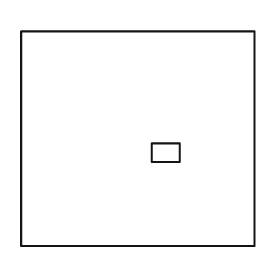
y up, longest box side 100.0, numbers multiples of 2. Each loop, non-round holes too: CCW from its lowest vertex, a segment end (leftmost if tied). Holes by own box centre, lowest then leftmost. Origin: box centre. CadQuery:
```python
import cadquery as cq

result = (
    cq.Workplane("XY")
    .moveTo(-50.0, -46.0)
    .lineTo(50.0, -46.0)
    .lineTo(50.0, 46.0)
    .lineTo(-50.0, 46.0)
    .close()
    .moveTo(6.0, -10.0)
    .lineTo(18.0, -10.0)
    .lineTo(18.0, -2.0)
    .lineTo(6.0, -2.0)
    .close()
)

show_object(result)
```